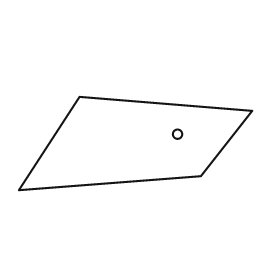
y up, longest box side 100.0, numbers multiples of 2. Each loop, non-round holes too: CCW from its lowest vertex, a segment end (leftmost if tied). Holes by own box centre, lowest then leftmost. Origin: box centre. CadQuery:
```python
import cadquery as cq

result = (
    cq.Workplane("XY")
    .moveTo(-50.0, -20.0)
    .lineTo(28.0, -14.0)
    .lineTo(50.0, 14.0)
    .lineTo(-24.0, 20.0)
    .close()
    .moveTo(18.0, 4.0)
    .circle(2.0)
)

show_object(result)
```